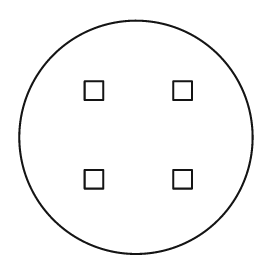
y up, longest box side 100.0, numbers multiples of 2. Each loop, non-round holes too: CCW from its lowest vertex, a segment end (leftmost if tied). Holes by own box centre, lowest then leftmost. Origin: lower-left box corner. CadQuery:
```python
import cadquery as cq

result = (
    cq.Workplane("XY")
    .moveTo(50.0, 50.0)
    .circle(50.0)
    .moveTo(28.0, 28.0)
    .lineTo(36.0, 28.0)
    .lineTo(36.0, 36.0)
    .lineTo(28.0, 36.0)
    .close()
    .moveTo(66.0, 28.0)
    .lineTo(74.0, 28.0)
    .lineTo(74.0, 36.0)
    .lineTo(66.0, 36.0)
    .close()
    .moveTo(28.0, 66.0)
    .lineTo(36.0, 66.0)
    .lineTo(36.0, 74.0)
    .lineTo(28.0, 74.0)
    .close()
    .moveTo(66.0, 66.0)
    .lineTo(74.0, 66.0)
    .lineTo(74.0, 74.0)
    .lineTo(66.0, 74.0)
    .close()
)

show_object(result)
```